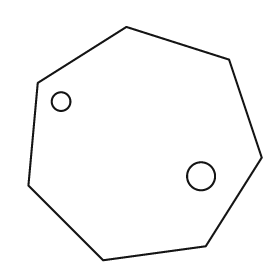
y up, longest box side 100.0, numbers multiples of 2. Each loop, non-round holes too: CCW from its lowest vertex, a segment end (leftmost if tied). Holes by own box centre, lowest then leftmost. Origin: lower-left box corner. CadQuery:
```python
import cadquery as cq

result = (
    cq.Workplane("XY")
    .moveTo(32.0, 0.0)
    .lineTo(76.0, 6.0)
    .lineTo(100.0, 44.0)
    .lineTo(86.0, 86.0)
    .lineTo(42.0, 100.0)
    .lineTo(4.0, 76.0)
    .lineTo(0.0, 32.0)
    .close()
    .moveTo(74.0, 36.0)
    .circle(6.0)
    .moveTo(14.0, 68.0)
    .circle(4.0)
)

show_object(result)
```